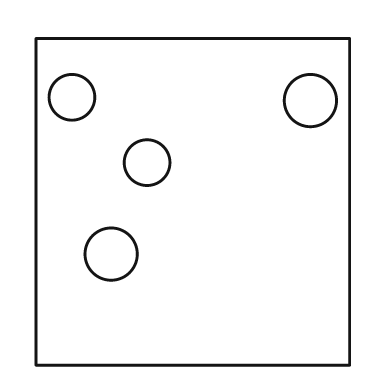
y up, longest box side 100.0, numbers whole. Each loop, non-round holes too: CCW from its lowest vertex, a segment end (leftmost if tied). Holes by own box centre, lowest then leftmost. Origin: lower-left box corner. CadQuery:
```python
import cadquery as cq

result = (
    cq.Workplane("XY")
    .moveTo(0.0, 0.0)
    .lineTo(96.0, 0.0)
    .lineTo(96.0, 100.0)
    .lineTo(0.0, 100.0)
    .close()
    .moveTo(23.0, 34.0)
    .circle(8.0)
    .moveTo(34.0, 62.0)
    .circle(7.0)
    .moveTo(84.0, 81.0)
    .circle(8.0)
    .moveTo(11.0, 82.0)
    .circle(7.0)
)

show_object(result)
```